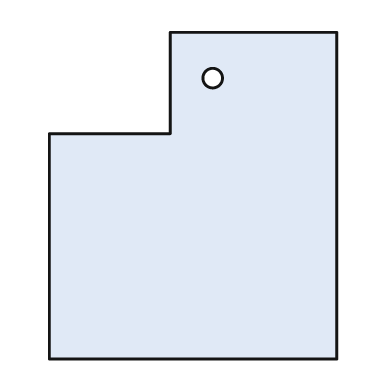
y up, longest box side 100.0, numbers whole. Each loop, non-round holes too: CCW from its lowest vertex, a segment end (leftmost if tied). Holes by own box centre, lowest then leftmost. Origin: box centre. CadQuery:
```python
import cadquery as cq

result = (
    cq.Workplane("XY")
    .moveTo(-44.0, -50.0)
    .lineTo(44.0, -50.0)
    .lineTo(44.0, 50.0)
    .lineTo(-7.0, 50.0)
    .lineTo(-7.0, 19.0)
    .lineTo(-44.0, 19.0)
    .close()
    .moveTo(6.0, 36.0)
    .circle(3.0)
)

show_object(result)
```